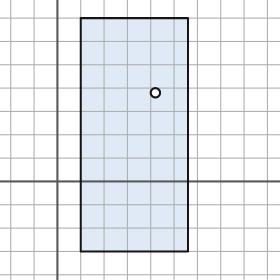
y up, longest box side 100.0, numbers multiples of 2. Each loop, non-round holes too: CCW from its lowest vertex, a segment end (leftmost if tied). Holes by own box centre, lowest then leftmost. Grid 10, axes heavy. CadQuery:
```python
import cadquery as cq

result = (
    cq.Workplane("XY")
    .moveTo(10.0, -30.0)
    .lineTo(56.0, -30.0)
    .lineTo(56.0, 70.0)
    .lineTo(10.0, 70.0)
    .close()
    .moveTo(42.0, 38.0)
    .circle(2.0)
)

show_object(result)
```